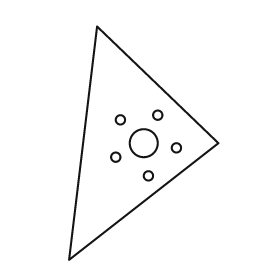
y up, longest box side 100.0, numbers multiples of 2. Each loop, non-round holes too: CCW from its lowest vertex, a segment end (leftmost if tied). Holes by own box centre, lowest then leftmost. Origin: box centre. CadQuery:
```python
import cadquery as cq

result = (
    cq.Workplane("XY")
    .moveTo(-32.0, -50.0)
    .lineTo(32.0, 0.0)
    .lineTo(-20.0, 50.0)
    .close()
    .moveTo(2.0, -14.0)
    .circle(2.0)
    .moveTo(-12.0, -6.0)
    .circle(2.0)
    .moveTo(14.0, -2.0)
    .circle(2.0)
    .moveTo(0.0, 0.0)
    .circle(6.0)
    .moveTo(-10.0, 10.0)
    .circle(2.0)
    .moveTo(6.0, 12.0)
    .circle(2.0)
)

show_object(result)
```